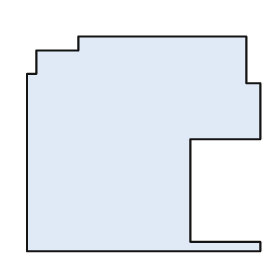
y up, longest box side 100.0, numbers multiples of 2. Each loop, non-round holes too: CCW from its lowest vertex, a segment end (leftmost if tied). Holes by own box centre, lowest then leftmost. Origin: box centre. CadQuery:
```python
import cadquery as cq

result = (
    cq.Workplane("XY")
    .moveTo(-50.0, -46.0)
    .lineTo(50.0, -46.0)
    .lineTo(50.0, -42.0)
    .lineTo(20.0, -42.0)
    .lineTo(20.0, 2.0)
    .lineTo(50.0, 2.0)
    .lineTo(50.0, 26.0)
    .lineTo(44.0, 26.0)
    .lineTo(44.0, 46.0)
    .lineTo(-28.0, 46.0)
    .lineTo(-28.0, 40.0)
    .lineTo(-46.0, 40.0)
    .lineTo(-46.0, 30.0)
    .lineTo(-50.0, 30.0)
    .close()
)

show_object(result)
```